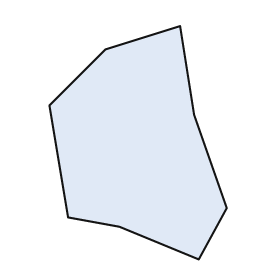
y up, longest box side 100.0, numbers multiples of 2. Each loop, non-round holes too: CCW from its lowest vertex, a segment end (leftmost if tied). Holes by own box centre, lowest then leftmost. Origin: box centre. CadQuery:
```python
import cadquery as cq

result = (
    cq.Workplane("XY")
    .moveTo(26.0, -50.0)
    .lineTo(38.0, -28.0)
    .lineTo(24.0, 12.0)
    .lineTo(18.0, 50.0)
    .lineTo(-14.0, 40.0)
    .lineTo(-38.0, 16.0)
    .lineTo(-30.0, -32.0)
    .lineTo(-8.0, -36.0)
    .close()
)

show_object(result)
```